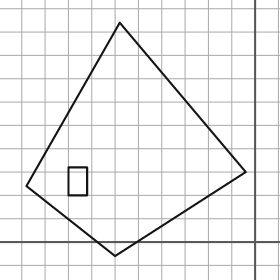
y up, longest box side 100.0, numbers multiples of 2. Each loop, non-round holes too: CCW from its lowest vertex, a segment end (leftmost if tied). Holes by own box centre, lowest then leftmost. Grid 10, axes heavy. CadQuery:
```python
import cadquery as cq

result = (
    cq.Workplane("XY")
    .moveTo(-60.0, -6.0)
    .lineTo(-4.0, 30.0)
    .lineTo(-58.0, 94.0)
    .lineTo(-98.0, 24.0)
    .close()
    .moveTo(-80.0, 20.0)
    .lineTo(-72.0, 20.0)
    .lineTo(-72.0, 32.0)
    .lineTo(-80.0, 32.0)
    .close()
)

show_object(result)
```